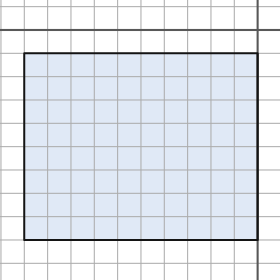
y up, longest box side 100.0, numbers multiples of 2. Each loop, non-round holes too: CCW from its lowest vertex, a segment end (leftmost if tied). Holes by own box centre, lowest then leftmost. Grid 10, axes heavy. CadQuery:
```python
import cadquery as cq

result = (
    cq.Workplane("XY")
    .moveTo(-100.0, -90.0)
    .lineTo(0.0, -90.0)
    .lineTo(0.0, -10.0)
    .lineTo(-100.0, -10.0)
    .close()
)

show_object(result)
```